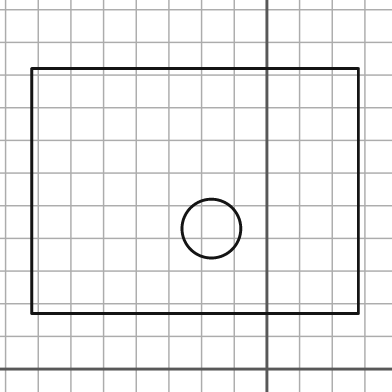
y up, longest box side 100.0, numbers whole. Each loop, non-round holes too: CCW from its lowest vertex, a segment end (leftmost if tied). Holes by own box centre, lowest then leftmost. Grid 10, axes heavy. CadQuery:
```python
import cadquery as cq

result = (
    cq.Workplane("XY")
    .moveTo(-72.0, 17.0)
    .lineTo(28.0, 17.0)
    .lineTo(28.0, 92.0)
    .lineTo(-72.0, 92.0)
    .close()
    .moveTo(-17.0, 43.0)
    .circle(9.0)
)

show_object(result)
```